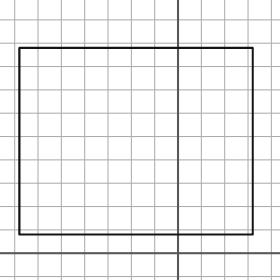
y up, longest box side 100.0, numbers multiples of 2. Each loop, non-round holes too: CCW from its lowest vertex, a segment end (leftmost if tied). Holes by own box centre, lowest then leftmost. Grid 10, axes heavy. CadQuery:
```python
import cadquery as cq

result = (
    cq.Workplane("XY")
    .moveTo(-68.0, 8.0)
    .lineTo(32.0, 8.0)
    .lineTo(32.0, 88.0)
    .lineTo(-68.0, 88.0)
    .close()
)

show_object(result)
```